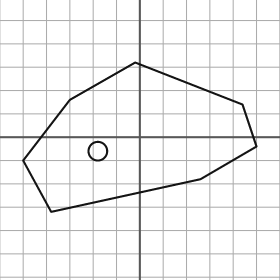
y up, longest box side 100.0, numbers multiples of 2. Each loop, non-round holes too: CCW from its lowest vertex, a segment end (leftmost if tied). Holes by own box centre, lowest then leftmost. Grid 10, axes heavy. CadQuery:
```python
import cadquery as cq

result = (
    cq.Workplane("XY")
    .moveTo(-38.0, -32.0)
    .lineTo(26.0, -18.0)
    .lineTo(50.0, -4.0)
    .lineTo(44.0, 14.0)
    .lineTo(-2.0, 32.0)
    .lineTo(-30.0, 16.0)
    .lineTo(-50.0, -10.0)
    .close()
    .moveTo(-18.0, -6.0)
    .circle(4.0)
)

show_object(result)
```